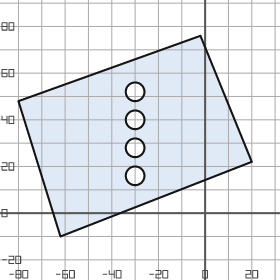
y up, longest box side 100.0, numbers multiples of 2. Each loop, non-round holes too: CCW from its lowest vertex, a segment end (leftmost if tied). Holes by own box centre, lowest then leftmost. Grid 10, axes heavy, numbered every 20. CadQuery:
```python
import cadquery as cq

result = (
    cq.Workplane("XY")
    .moveTo(-62.0, -10.0)
    .lineTo(20.0, 22.0)
    .lineTo(-2.0, 76.0)
    .lineTo(-80.0, 48.0)
    .close()
    .moveTo(-30.0, 16.0)
    .circle(4.0)
    .moveTo(-30.0, 28.0)
    .circle(4.0)
    .moveTo(-30.0, 40.0)
    .circle(4.0)
    .moveTo(-30.0, 52.0)
    .circle(4.0)
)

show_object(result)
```